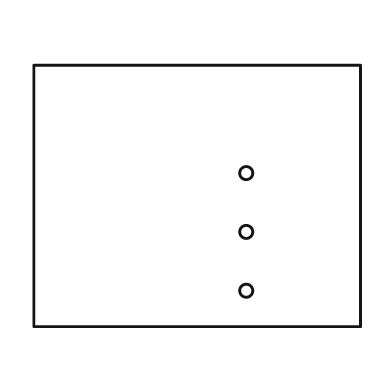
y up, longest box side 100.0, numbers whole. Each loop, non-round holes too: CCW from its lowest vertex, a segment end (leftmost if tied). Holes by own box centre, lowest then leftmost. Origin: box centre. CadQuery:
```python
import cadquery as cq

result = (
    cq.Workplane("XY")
    .moveTo(-50.0, -40.0)
    .lineTo(50.0, -40.0)
    .lineTo(50.0, 40.0)
    .lineTo(-50.0, 40.0)
    .close()
    .moveTo(15.0, -29.0)
    .circle(2.0)
    .moveTo(15.0, -11.0)
    .circle(2.0)
    .moveTo(15.0, 7.0)
    .circle(2.0)
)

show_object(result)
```